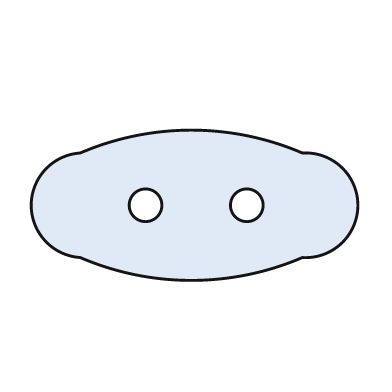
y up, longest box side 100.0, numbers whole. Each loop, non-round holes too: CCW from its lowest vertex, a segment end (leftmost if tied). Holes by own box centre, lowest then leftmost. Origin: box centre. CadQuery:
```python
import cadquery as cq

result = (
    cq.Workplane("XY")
    .moveTo(-35.0, -16.0)
    .threePointArc((-1.0, -23.0), (33.0, -16.0))
    .threePointArc((50.0, 0.0), (33.0, 16.0))
    .threePointArc((-1.0, 23.0), (-35.0, 16.0))
    .threePointArc((-50.0, 0.0), (-35.0, -16.0))
    .close()
    .moveTo(-15.0, 0.0)
    .circle(5.0)
    .moveTo(16.0, 0.0)
    .circle(5.0)
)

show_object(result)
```